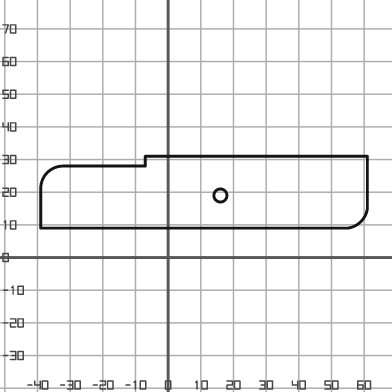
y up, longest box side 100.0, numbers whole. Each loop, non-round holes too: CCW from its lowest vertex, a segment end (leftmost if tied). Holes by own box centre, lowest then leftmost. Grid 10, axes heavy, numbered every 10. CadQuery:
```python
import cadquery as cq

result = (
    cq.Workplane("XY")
    .moveTo(-39.0, 9.0)
    .lineTo(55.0, 9.0)
    .threePointArc((59.0, 11.0), (61.0, 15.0))
    .lineTo(61.0, 31.0)
    .lineTo(-7.0, 31.0)
    .lineTo(-7.0, 28.0)
    .lineTo(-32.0, 28.0)
    .threePointArc((-37.0, 26.0), (-39.0, 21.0))
    .close()
    .moveTo(16.0, 19.0)
    .circle(2.0)
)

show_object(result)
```